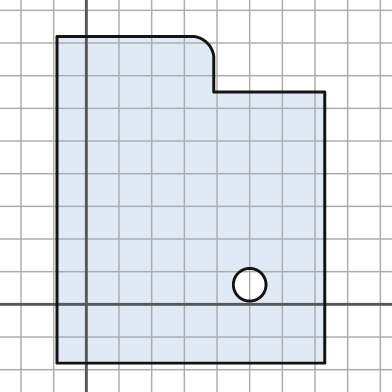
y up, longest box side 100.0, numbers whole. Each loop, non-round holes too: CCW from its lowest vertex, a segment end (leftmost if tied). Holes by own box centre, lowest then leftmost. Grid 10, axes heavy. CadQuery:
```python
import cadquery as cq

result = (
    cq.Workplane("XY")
    .moveTo(-9.0, -18.0)
    .lineTo(73.0, -18.0)
    .lineTo(73.0, 65.0)
    .lineTo(39.0, 65.0)
    .lineTo(39.0, 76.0)
    .threePointArc((37.0, 80.0), (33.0, 82.0))
    .lineTo(-9.0, 82.0)
    .close()
    .moveTo(50.0, 6.0)
    .circle(5.0)
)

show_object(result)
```